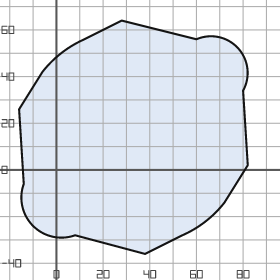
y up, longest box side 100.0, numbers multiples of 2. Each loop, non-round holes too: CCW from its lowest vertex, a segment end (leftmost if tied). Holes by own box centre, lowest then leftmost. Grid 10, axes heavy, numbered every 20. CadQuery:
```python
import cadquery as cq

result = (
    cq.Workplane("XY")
    .moveTo(38.0, -36.0)
    .lineTo(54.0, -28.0)
    .threePointArc((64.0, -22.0), (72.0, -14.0))
    .lineTo(82.0, 2.0)
    .lineTo(80.0, 34.0)
    .threePointArc((78.0, 52.0), (60.0, 56.0))
    .lineTo(28.0, 64.0)
    .lineTo(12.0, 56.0)
    .threePointArc((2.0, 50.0), (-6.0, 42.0))
    .lineTo(-16.0, 26.0)
    .lineTo(-14.0, -6.0)
    .threePointArc((-10.0, -24.0), (8.0, -28.0))
    .close()
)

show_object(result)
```